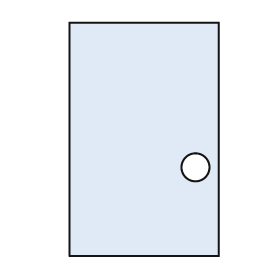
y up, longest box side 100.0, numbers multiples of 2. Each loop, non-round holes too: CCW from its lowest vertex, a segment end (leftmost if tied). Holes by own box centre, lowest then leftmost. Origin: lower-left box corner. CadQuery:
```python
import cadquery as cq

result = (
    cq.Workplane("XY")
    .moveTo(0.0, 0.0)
    .lineTo(64.0, 0.0)
    .lineTo(64.0, 100.0)
    .lineTo(0.0, 100.0)
    .close()
    .moveTo(54.0, 38.0)
    .circle(6.0)
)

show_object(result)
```